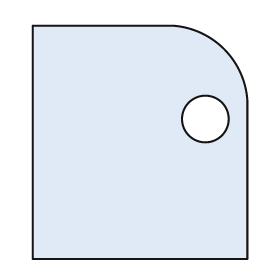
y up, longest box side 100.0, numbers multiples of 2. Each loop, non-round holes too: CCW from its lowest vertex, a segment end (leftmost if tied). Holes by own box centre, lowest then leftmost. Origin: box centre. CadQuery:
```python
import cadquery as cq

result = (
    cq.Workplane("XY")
    .moveTo(-46.0, -50.0)
    .lineTo(46.0, -50.0)
    .lineTo(46.0, 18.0)
    .threePointArc((36.0, 40.0), (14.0, 50.0))
    .lineTo(-46.0, 50.0)
    .close()
    .moveTo(28.0, 10.0)
    .circle(10.0)
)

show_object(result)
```